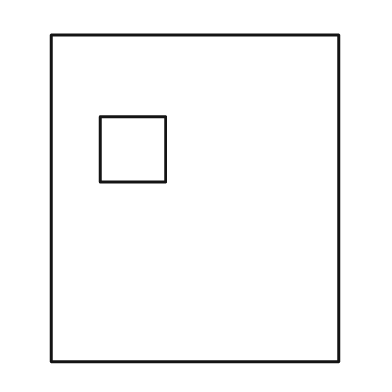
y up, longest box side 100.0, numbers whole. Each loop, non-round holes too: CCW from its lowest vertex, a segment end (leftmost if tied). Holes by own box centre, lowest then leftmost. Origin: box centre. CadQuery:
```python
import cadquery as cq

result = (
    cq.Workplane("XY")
    .moveTo(-44.0, -50.0)
    .lineTo(44.0, -50.0)
    .lineTo(44.0, 50.0)
    .lineTo(-44.0, 50.0)
    .close()
    .moveTo(-29.0, 5.0)
    .lineTo(-9.0, 5.0)
    .lineTo(-9.0, 25.0)
    .lineTo(-29.0, 25.0)
    .close()
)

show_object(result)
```